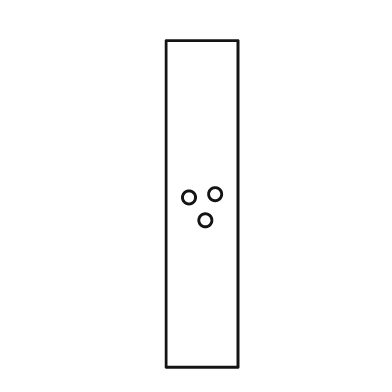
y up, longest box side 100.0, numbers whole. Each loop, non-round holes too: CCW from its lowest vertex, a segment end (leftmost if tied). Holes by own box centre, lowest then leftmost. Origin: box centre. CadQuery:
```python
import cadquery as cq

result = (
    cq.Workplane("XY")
    .moveTo(-11.0, -50.0)
    .lineTo(11.0, -50.0)
    .lineTo(11.0, 50.0)
    .lineTo(-11.0, 50.0)
    .close()
    .moveTo(1.0, -5.0)
    .circle(2.0)
    .moveTo(-4.0, 2.0)
    .circle(2.0)
    .moveTo(4.0, 3.0)
    .circle(2.0)
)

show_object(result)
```